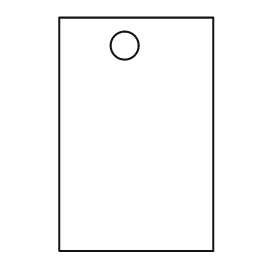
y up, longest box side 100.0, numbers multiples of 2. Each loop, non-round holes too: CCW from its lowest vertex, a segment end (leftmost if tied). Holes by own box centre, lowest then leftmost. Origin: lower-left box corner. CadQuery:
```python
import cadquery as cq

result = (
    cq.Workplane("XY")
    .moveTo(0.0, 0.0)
    .lineTo(66.0, 0.0)
    .lineTo(66.0, 100.0)
    .lineTo(0.0, 100.0)
    .close()
    .moveTo(28.0, 88.0)
    .circle(6.0)
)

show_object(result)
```